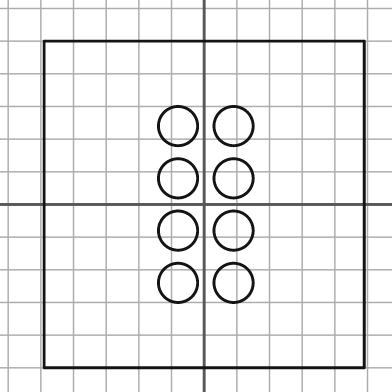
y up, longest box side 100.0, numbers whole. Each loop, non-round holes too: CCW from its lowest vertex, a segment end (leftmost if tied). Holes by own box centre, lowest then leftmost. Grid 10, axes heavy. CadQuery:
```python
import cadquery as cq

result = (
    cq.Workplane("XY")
    .moveTo(-49.0, -50.0)
    .lineTo(49.0, -50.0)
    .lineTo(49.0, 50.0)
    .lineTo(-49.0, 50.0)
    .close()
    .moveTo(-8.0, -24.0)
    .circle(6.0)
    .moveTo(9.0, -24.0)
    .circle(6.0)
    .moveTo(-8.0, -8.0)
    .circle(6.0)
    .moveTo(9.0, -8.0)
    .circle(6.0)
    .moveTo(-8.0, 8.0)
    .circle(6.0)
    .moveTo(9.0, 8.0)
    .circle(6.0)
    .moveTo(-8.0, 24.0)
    .circle(6.0)
    .moveTo(9.0, 24.0)
    .circle(6.0)
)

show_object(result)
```